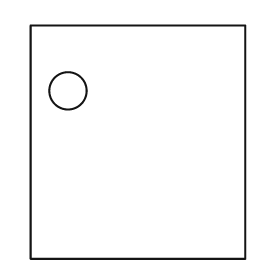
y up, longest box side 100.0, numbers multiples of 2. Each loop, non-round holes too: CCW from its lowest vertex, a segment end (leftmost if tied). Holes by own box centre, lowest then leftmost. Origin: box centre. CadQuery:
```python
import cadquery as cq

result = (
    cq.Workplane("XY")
    .moveTo(-46.0, -50.0)
    .lineTo(46.0, -50.0)
    .lineTo(46.0, 50.0)
    .lineTo(-46.0, 50.0)
    .close()
    .moveTo(-30.0, 22.0)
    .circle(8.0)
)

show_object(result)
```